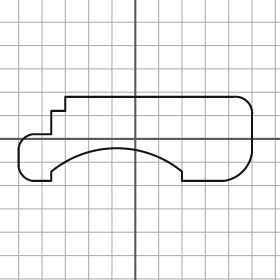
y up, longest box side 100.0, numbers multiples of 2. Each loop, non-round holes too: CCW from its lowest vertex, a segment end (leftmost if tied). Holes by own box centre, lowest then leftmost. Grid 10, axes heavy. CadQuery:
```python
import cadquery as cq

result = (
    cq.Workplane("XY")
    .moveTo(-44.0, -18.0)
    .lineTo(-36.0, -18.0)
    .lineTo(-36.0, -14.0)
    .threePointArc((-8.0, -4.0), (20.0, -14.0))
    .lineTo(20.0, -18.0)
    .lineTo(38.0, -18.0)
    .threePointArc((46.0, -14.0), (50.0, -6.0))
    .lineTo(50.0, 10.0)
    .threePointArc((48.0, 16.0), (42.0, 18.0))
    .lineTo(-30.0, 18.0)
    .lineTo(-30.0, 12.0)
    .lineTo(-36.0, 12.0)
    .lineTo(-36.0, 2.0)
    .lineTo(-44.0, 2.0)
    .threePointArc((-48.0, 0.0), (-50.0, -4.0))
    .lineTo(-50.0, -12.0)
    .threePointArc((-48.0, -16.0), (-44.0, -18.0))
    .close()
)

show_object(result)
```